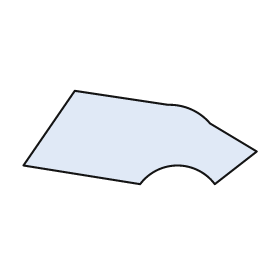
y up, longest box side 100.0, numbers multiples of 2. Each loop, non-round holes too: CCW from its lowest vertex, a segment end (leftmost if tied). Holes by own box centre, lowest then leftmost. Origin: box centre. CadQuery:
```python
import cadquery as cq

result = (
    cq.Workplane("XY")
    .moveTo(0.0, -20.0)
    .threePointArc((16.0, -12.0), (32.0, -20.0))
    .lineTo(50.0, -6.0)
    .lineTo(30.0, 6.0)
    .threePointArc((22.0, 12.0), (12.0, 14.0))
    .lineTo(-28.0, 20.0)
    .lineTo(-50.0, -12.0)
    .close()
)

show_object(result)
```